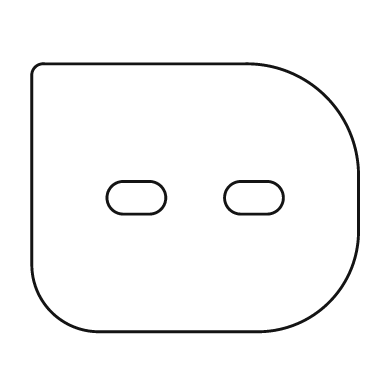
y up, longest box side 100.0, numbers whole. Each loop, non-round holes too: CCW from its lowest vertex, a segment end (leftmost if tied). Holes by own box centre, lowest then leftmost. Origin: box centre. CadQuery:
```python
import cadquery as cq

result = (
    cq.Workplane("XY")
    .moveTo(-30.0, -41.0)
    .lineTo(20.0, -41.0)
    .threePointArc((41.0, -32.0), (50.0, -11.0))
    .lineTo(50.0, 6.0)
    .threePointArc((40.0, 31.0), (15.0, 41.0))
    .lineTo(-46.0, 41.0)
    .threePointArc((-49.0, 40.0), (-50.0, 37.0))
    .lineTo(-50.0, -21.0)
    .threePointArc((-44.0, -35.0), (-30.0, -41.0))
    .close()
    .moveTo(-22.0, -5.0)
    .lineTo(-14.0, -5.0)
    .threePointArc((-9.0, 0.0), (-14.0, 5.0))
    .lineTo(-22.0, 5.0)
    .threePointArc((-27.0, 0.0), (-22.0, -5.0))
    .close()
    .moveTo(14.0, -5.0)
    .lineTo(22.0, -5.0)
    .threePointArc((27.0, 0.0), (22.0, 5.0))
    .lineTo(14.0, 5.0)
    .threePointArc((9.0, 0.0), (14.0, -5.0))
    .close()
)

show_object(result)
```